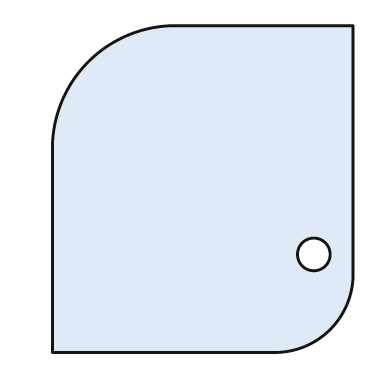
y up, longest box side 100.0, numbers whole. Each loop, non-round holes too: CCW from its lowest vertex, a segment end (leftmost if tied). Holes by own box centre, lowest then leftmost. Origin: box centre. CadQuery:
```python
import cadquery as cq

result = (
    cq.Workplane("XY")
    .moveTo(-46.0, -50.0)
    .lineTo(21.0, -50.0)
    .threePointArc((39.0, -43.0), (46.0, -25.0))
    .lineTo(46.0, 50.0)
    .lineTo(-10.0, 50.0)
    .threePointArc((-35.0, 39.0), (-46.0, 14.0))
    .close()
    .moveTo(34.0, -20.0)
    .circle(5.0)
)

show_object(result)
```